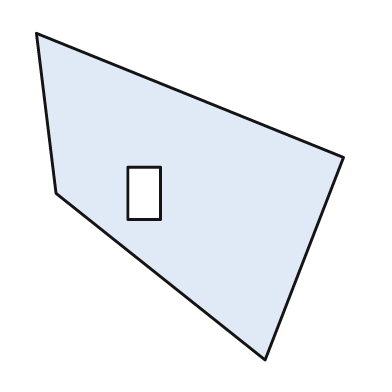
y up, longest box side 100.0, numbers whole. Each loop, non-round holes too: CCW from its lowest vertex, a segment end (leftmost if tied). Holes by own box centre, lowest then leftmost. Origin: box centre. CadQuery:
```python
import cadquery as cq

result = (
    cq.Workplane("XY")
    .moveTo(23.0, -50.0)
    .lineTo(47.0, 12.0)
    .lineTo(-47.0, 50.0)
    .lineTo(-41.0, 1.0)
    .close()
    .moveTo(-19.0, -7.0)
    .lineTo(-9.0, -7.0)
    .lineTo(-9.0, 9.0)
    .lineTo(-19.0, 9.0)
    .close()
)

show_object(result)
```